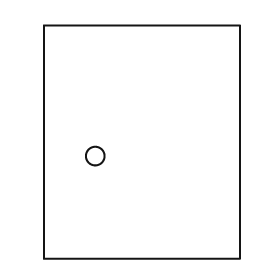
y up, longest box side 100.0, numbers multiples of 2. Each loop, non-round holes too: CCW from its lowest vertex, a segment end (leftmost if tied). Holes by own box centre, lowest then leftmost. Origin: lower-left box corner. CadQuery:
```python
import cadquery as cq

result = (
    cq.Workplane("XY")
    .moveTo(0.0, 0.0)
    .lineTo(84.0, 0.0)
    .lineTo(84.0, 100.0)
    .lineTo(0.0, 100.0)
    .close()
    .moveTo(22.0, 44.0)
    .circle(4.0)
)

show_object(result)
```